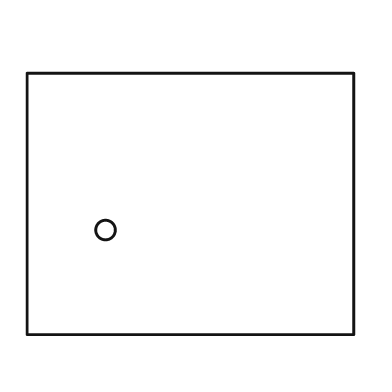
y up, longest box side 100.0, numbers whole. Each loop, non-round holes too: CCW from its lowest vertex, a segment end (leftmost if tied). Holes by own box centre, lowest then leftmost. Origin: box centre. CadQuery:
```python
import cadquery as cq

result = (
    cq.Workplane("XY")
    .moveTo(-50.0, -40.0)
    .lineTo(50.0, -40.0)
    .lineTo(50.0, 40.0)
    .lineTo(-50.0, 40.0)
    .close()
    .moveTo(-26.0, -8.0)
    .circle(3.0)
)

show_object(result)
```